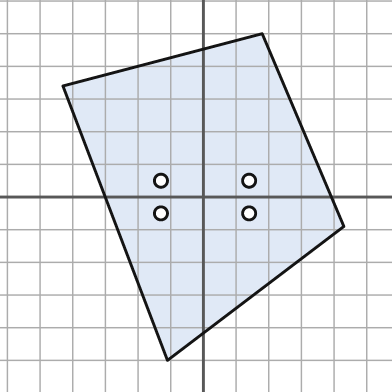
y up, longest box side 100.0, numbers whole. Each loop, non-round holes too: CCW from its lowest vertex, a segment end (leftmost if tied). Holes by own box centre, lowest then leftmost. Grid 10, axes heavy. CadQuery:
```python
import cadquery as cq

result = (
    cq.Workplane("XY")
    .moveTo(-11.0, -50.0)
    .lineTo(43.0, -9.0)
    .lineTo(18.0, 50.0)
    .lineTo(-43.0, 34.0)
    .close()
    .moveTo(-13.0, -5.0)
    .circle(2.0)
    .moveTo(14.0, -5.0)
    .circle(2.0)
    .moveTo(-13.0, 5.0)
    .circle(2.0)
    .moveTo(14.0, 5.0)
    .circle(2.0)
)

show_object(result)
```